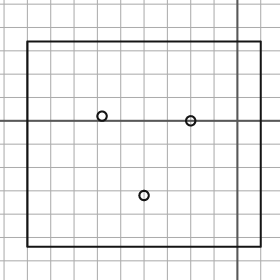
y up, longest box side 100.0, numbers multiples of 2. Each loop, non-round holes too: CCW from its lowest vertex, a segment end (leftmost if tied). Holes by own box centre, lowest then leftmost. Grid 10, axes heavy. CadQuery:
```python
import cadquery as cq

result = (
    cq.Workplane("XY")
    .moveTo(-90.0, -54.0)
    .lineTo(10.0, -54.0)
    .lineTo(10.0, 34.0)
    .lineTo(-90.0, 34.0)
    .close()
    .moveTo(-40.0, -32.0)
    .circle(2.0)
    .moveTo(-20.0, 0.0)
    .circle(2.0)
    .moveTo(-58.0, 2.0)
    .circle(2.0)
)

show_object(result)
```